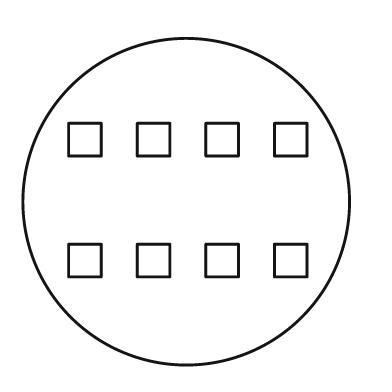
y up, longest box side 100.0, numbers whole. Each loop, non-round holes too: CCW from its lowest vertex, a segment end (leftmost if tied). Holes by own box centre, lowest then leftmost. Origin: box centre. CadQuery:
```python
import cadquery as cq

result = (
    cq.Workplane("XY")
    .moveTo(0.0, 0.0)
    .circle(50.0)
    .moveTo(-36.0, -23.0)
    .lineTo(-26.0, -23.0)
    .lineTo(-26.0, -13.0)
    .lineTo(-36.0, -13.0)
    .close()
    .moveTo(-15.0, -23.0)
    .lineTo(-5.0, -23.0)
    .lineTo(-5.0, -13.0)
    .lineTo(-15.0, -13.0)
    .close()
    .moveTo(6.0, -23.0)
    .lineTo(16.0, -23.0)
    .lineTo(16.0, -13.0)
    .lineTo(6.0, -13.0)
    .close()
    .moveTo(27.0, -23.0)
    .lineTo(37.0, -23.0)
    .lineTo(37.0, -13.0)
    .lineTo(27.0, -13.0)
    .close()
    .moveTo(-36.0, 14.0)
    .lineTo(-26.0, 14.0)
    .lineTo(-26.0, 24.0)
    .lineTo(-36.0, 24.0)
    .close()
    .moveTo(-15.0, 14.0)
    .lineTo(-5.0, 14.0)
    .lineTo(-5.0, 24.0)
    .lineTo(-15.0, 24.0)
    .close()
    .moveTo(6.0, 14.0)
    .lineTo(16.0, 14.0)
    .lineTo(16.0, 24.0)
    .lineTo(6.0, 24.0)
    .close()
    .moveTo(27.0, 14.0)
    .lineTo(37.0, 14.0)
    .lineTo(37.0, 24.0)
    .lineTo(27.0, 24.0)
    .close()
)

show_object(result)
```